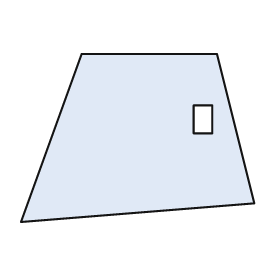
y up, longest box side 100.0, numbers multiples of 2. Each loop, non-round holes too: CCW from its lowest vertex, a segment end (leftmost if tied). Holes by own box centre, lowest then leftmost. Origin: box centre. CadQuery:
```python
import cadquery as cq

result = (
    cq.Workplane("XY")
    .moveTo(-50.0, -36.0)
    .lineTo(50.0, -28.0)
    .lineTo(34.0, 36.0)
    .lineTo(-24.0, 36.0)
    .close()
    .moveTo(24.0, 2.0)
    .lineTo(32.0, 2.0)
    .lineTo(32.0, 14.0)
    .lineTo(24.0, 14.0)
    .close()
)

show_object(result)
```